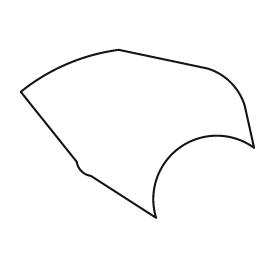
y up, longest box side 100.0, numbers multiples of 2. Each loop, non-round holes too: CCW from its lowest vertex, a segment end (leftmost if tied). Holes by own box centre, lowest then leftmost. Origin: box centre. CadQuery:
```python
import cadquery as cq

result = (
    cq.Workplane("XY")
    .moveTo(8.0, -36.0)
    .threePointArc((18.0, -6.0), (50.0, -6.0))
    .lineTo(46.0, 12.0)
    .threePointArc((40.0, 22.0), (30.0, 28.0))
    .lineTo(-8.0, 36.0)
    .threePointArc((-30.0, 30.0), (-50.0, 18.0))
    .lineTo(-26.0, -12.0)
    .threePointArc((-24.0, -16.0), (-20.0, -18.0))
    .close()
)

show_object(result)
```